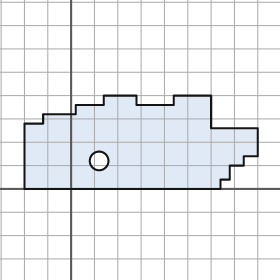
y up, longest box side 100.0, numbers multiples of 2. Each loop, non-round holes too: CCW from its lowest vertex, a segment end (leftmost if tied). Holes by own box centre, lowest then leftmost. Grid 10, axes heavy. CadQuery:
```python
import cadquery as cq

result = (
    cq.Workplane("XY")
    .moveTo(-20.0, 0.0)
    .lineTo(64.0, 0.0)
    .lineTo(64.0, 4.0)
    .lineTo(68.0, 4.0)
    .lineTo(68.0, 10.0)
    .lineTo(74.0, 10.0)
    .lineTo(74.0, 14.0)
    .lineTo(80.0, 14.0)
    .lineTo(80.0, 26.0)
    .lineTo(60.0, 26.0)
    .lineTo(60.0, 40.0)
    .lineTo(44.0, 40.0)
    .lineTo(44.0, 36.0)
    .lineTo(28.0, 36.0)
    .lineTo(28.0, 40.0)
    .lineTo(14.0, 40.0)
    .lineTo(14.0, 36.0)
    .lineTo(2.0, 36.0)
    .lineTo(2.0, 32.0)
    .lineTo(-12.0, 32.0)
    .lineTo(-12.0, 28.0)
    .lineTo(-20.0, 28.0)
    .close()
    .moveTo(12.0, 12.0)
    .circle(4.0)
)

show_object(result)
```